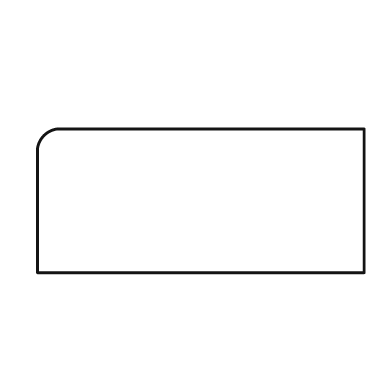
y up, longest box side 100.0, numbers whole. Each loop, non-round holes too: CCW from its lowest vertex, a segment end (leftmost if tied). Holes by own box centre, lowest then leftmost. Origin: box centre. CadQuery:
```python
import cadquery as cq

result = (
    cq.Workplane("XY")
    .moveTo(-50.0, -22.0)
    .lineTo(50.0, -22.0)
    .lineTo(50.0, 22.0)
    .lineTo(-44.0, 22.0)
    .threePointArc((-48.0, 20.0), (-50.0, 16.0))
    .close()
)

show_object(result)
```